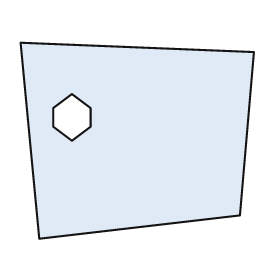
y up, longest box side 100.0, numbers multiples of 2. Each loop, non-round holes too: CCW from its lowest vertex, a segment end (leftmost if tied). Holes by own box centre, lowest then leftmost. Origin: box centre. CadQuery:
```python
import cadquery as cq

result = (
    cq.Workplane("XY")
    .moveTo(-42.0, -42.0)
    .lineTo(44.0, -32.0)
    .lineTo(50.0, 38.0)
    .lineTo(-50.0, 42.0)
    .close()
    .moveTo(-28.0, 0.0)
    .lineTo(-20.0, 6.0)
    .lineTo(-20.0, 14.0)
    .lineTo(-28.0, 20.0)
    .lineTo(-36.0, 14.0)
    .lineTo(-36.0, 6.0)
    .close()
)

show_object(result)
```